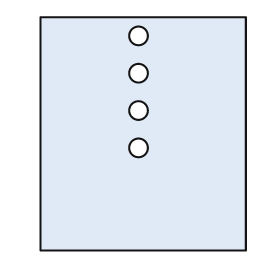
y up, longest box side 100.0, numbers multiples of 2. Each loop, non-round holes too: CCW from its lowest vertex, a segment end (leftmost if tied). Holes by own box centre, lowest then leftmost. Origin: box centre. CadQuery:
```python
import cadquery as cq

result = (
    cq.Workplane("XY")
    .moveTo(-44.0, -50.0)
    .lineTo(44.0, -50.0)
    .lineTo(44.0, 50.0)
    .lineTo(-44.0, 50.0)
    .close()
    .moveTo(-2.0, -6.0)
    .circle(4.0)
    .moveTo(-2.0, 10.0)
    .circle(4.0)
    .moveTo(-2.0, 26.0)
    .circle(4.0)
    .moveTo(-2.0, 42.0)
    .circle(4.0)
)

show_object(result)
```